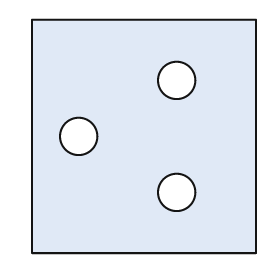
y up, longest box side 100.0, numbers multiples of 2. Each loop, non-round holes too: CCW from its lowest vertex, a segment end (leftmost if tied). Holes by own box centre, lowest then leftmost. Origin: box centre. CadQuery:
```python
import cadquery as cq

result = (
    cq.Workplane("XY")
    .moveTo(-48.0, -50.0)
    .lineTo(48.0, -50.0)
    .lineTo(48.0, 50.0)
    .lineTo(-48.0, 50.0)
    .close()
    .moveTo(14.0, -24.0)
    .circle(8.0)
    .moveTo(-28.0, 0.0)
    .circle(8.0)
    .moveTo(14.0, 24.0)
    .circle(8.0)
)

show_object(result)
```